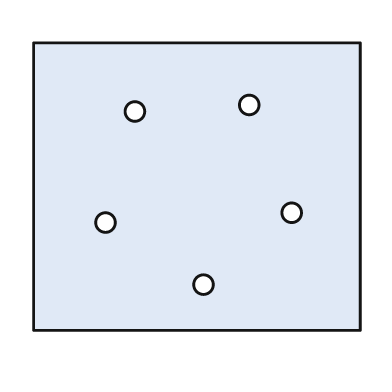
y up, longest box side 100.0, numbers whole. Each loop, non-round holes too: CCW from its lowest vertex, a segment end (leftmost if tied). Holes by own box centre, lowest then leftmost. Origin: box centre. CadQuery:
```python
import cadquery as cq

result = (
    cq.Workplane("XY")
    .moveTo(-50.0, -44.0)
    .lineTo(50.0, -44.0)
    .lineTo(50.0, 44.0)
    .lineTo(-50.0, 44.0)
    .close()
    .moveTo(2.0, -30.0)
    .circle(3.0)
    .moveTo(-28.0, -11.0)
    .circle(3.0)
    .moveTo(29.0, -8.0)
    .circle(3.0)
    .moveTo(-19.0, 23.0)
    .circle(3.0)
    .moveTo(16.0, 25.0)
    .circle(3.0)
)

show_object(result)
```